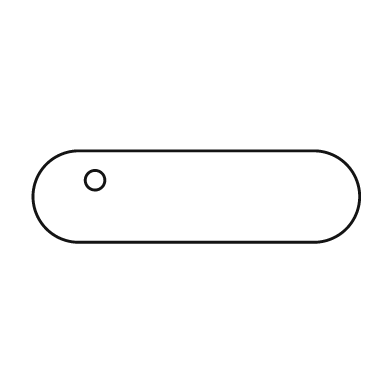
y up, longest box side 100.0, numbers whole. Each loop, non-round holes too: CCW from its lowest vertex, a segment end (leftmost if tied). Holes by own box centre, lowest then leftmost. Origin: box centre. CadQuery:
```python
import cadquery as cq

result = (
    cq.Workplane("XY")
    .moveTo(-36.0, -14.0)
    .lineTo(36.0, -14.0)
    .threePointArc((50.0, 0.0), (36.0, 14.0))
    .lineTo(-36.0, 14.0)
    .threePointArc((-50.0, 0.0), (-36.0, -14.0))
    .close()
    .moveTo(-31.0, 5.0)
    .circle(3.0)
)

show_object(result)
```